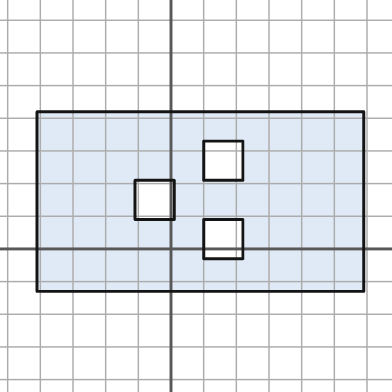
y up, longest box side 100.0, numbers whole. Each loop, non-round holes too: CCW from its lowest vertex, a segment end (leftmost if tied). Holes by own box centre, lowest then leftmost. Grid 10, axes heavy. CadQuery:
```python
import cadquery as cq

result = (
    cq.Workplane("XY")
    .moveTo(-41.0, -13.0)
    .lineTo(59.0, -13.0)
    .lineTo(59.0, 42.0)
    .lineTo(-41.0, 42.0)
    .close()
    .moveTo(10.0, -3.0)
    .lineTo(22.0, -3.0)
    .lineTo(22.0, 9.0)
    .lineTo(10.0, 9.0)
    .close()
    .moveTo(-11.0, 9.0)
    .lineTo(1.0, 9.0)
    .lineTo(1.0, 21.0)
    .lineTo(-11.0, 21.0)
    .close()
    .moveTo(10.0, 21.0)
    .lineTo(22.0, 21.0)
    .lineTo(22.0, 33.0)
    .lineTo(10.0, 33.0)
    .close()
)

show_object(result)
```